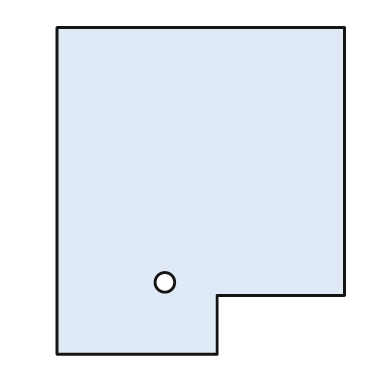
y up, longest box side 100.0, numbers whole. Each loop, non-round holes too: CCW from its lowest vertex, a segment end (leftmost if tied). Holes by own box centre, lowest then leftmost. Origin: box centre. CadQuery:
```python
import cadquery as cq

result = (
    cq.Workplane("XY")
    .moveTo(-44.0, -50.0)
    .lineTo(5.0, -50.0)
    .lineTo(5.0, -32.0)
    .lineTo(44.0, -32.0)
    .lineTo(44.0, 50.0)
    .lineTo(-44.0, 50.0)
    .close()
    .moveTo(-11.0, -28.0)
    .circle(3.0)
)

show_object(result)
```